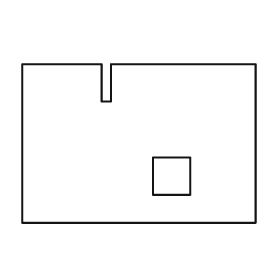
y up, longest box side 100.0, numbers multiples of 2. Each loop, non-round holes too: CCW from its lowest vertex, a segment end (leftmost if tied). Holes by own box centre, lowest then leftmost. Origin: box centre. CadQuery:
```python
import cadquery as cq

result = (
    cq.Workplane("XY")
    .moveTo(-50.0, -34.0)
    .lineTo(50.0, -34.0)
    .lineTo(50.0, 34.0)
    .lineTo(-12.0, 34.0)
    .lineTo(-12.0, 18.0)
    .lineTo(-16.0, 18.0)
    .lineTo(-16.0, 34.0)
    .lineTo(-50.0, 34.0)
    .close()
    .moveTo(6.0, -22.0)
    .lineTo(22.0, -22.0)
    .lineTo(22.0, -6.0)
    .lineTo(6.0, -6.0)
    .close()
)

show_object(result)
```